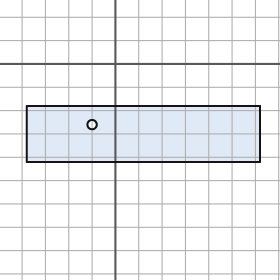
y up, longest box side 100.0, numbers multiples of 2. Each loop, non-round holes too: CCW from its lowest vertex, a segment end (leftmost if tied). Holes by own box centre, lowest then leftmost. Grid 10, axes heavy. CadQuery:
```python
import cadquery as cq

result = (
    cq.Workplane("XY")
    .moveTo(-38.0, -42.0)
    .lineTo(62.0, -42.0)
    .lineTo(62.0, -18.0)
    .lineTo(-38.0, -18.0)
    .close()
    .moveTo(-10.0, -26.0)
    .circle(2.0)
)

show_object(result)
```